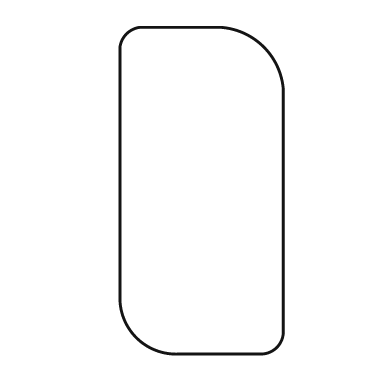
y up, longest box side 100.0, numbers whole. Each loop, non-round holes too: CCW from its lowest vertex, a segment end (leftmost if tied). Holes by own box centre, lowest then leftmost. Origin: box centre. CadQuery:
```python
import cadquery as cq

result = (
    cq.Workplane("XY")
    .moveTo(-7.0, -50.0)
    .lineTo(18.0, -50.0)
    .threePointArc((23.0, -48.0), (25.0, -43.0))
    .lineTo(25.0, 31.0)
    .threePointArc((19.0, 44.0), (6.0, 50.0))
    .lineTo(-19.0, 50.0)
    .threePointArc((-23.0, 48.0), (-25.0, 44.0))
    .lineTo(-25.0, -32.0)
    .threePointArc((-20.0, -45.0), (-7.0, -50.0))
    .close()
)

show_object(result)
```